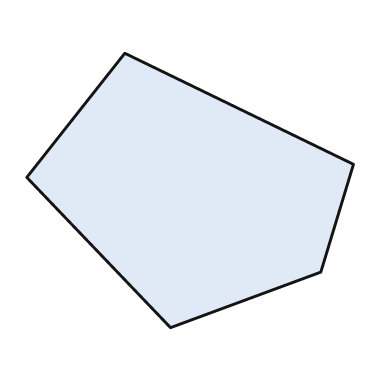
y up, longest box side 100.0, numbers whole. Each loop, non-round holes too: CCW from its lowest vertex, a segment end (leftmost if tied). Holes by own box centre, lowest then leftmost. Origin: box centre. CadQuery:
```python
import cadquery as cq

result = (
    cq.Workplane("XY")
    .moveTo(-6.0, -42.0)
    .lineTo(40.0, -25.0)
    .lineTo(50.0, 8.0)
    .lineTo(-20.0, 42.0)
    .lineTo(-50.0, 4.0)
    .close()
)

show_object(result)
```